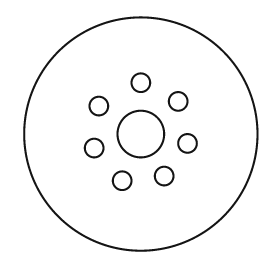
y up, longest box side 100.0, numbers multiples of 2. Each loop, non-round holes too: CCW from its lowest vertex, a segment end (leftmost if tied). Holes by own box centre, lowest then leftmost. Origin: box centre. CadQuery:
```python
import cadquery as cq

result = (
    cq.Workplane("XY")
    .moveTo(0.0, 0.0)
    .circle(50.0)
    .moveTo(-8.0, -20.0)
    .circle(4.0)
    .moveTo(10.0, -18.0)
    .circle(4.0)
    .moveTo(-20.0, -6.0)
    .circle(4.0)
    .moveTo(20.0, -4.0)
    .circle(4.0)
    .moveTo(0.0, 0.0)
    .circle(10.0)
    .moveTo(-18.0, 12.0)
    .circle(4.0)
    .moveTo(16.0, 14.0)
    .circle(4.0)
    .moveTo(0.0, 22.0)
    .circle(4.0)
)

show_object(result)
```